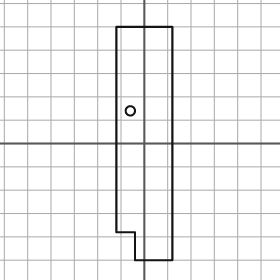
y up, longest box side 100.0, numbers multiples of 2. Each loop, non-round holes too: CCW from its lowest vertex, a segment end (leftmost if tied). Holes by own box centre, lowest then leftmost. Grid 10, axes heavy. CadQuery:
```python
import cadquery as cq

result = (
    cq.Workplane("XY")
    .moveTo(-4.0, -50.0)
    .lineTo(12.0, -50.0)
    .lineTo(12.0, 50.0)
    .lineTo(-12.0, 50.0)
    .lineTo(-12.0, -38.0)
    .lineTo(-4.0, -38.0)
    .close()
    .moveTo(-6.0, 14.0)
    .circle(2.0)
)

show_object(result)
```